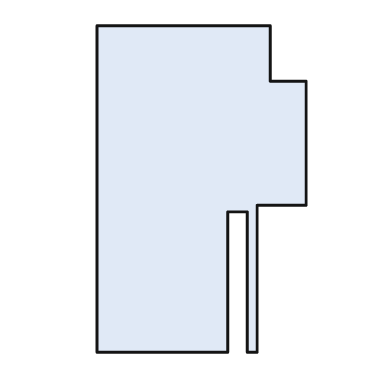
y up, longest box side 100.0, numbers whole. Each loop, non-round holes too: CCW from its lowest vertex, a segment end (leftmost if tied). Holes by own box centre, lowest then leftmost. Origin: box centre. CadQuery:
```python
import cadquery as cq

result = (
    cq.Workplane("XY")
    .moveTo(-32.0, -50.0)
    .lineTo(8.0, -50.0)
    .lineTo(8.0, -7.0)
    .lineTo(14.0, -7.0)
    .lineTo(14.0, -50.0)
    .lineTo(17.0, -50.0)
    .lineTo(17.0, -5.0)
    .lineTo(32.0, -5.0)
    .lineTo(32.0, 33.0)
    .lineTo(21.0, 33.0)
    .lineTo(21.0, 50.0)
    .lineTo(-32.0, 50.0)
    .close()
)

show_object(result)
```